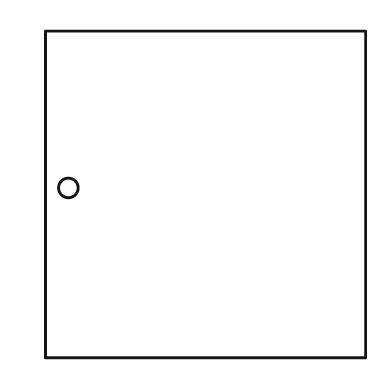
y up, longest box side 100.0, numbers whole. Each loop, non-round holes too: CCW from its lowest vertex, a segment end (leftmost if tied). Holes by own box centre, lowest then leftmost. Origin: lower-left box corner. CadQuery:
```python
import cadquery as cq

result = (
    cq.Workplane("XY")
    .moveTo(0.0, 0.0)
    .lineTo(98.0, 0.0)
    .lineTo(98.0, 100.0)
    .lineTo(0.0, 100.0)
    .close()
    .moveTo(7.0, 52.0)
    .circle(3.0)
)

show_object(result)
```